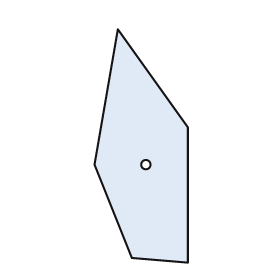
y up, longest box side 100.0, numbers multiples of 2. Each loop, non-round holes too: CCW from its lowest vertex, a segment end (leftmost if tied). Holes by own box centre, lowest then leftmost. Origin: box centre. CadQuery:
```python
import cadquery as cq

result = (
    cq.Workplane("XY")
    .moveTo(20.0, -50.0)
    .lineTo(20.0, 8.0)
    .lineTo(-10.0, 50.0)
    .lineTo(-20.0, -8.0)
    .lineTo(-4.0, -48.0)
    .close()
    .moveTo(2.0, -8.0)
    .circle(2.0)
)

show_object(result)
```